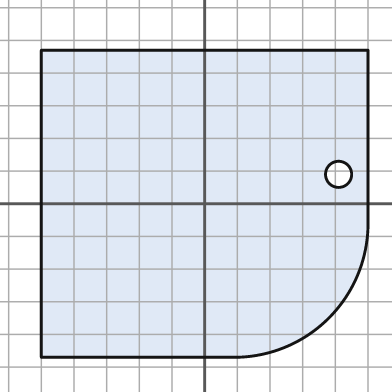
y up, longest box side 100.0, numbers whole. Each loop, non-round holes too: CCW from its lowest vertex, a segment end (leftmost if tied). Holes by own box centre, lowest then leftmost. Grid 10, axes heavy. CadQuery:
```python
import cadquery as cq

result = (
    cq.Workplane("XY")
    .moveTo(-50.0, -47.0)
    .lineTo(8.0, -47.0)
    .threePointArc((38.0, -35.0), (50.0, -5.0))
    .lineTo(50.0, 47.0)
    .lineTo(-50.0, 47.0)
    .close()
    .moveTo(41.0, 9.0)
    .circle(4.0)
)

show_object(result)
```